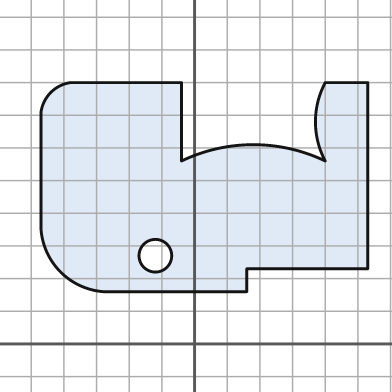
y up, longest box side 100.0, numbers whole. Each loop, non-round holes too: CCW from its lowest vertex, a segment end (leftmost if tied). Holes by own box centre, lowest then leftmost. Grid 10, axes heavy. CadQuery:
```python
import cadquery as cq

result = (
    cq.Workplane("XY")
    .moveTo(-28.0, 16.0)
    .lineTo(16.0, 16.0)
    .lineTo(16.0, 23.0)
    .lineTo(53.0, 23.0)
    .lineTo(53.0, 80.0)
    .lineTo(40.0, 80.0)
    .threePointArc((37.0, 68.0), (40.0, 56.0))
    .threePointArc((18.0, 61.0), (-4.0, 56.0))
    .lineTo(-4.0, 80.0)
    .lineTo(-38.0, 80.0)
    .threePointArc((-44.0, 77.0), (-47.0, 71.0))
    .lineTo(-47.0, 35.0)
    .threePointArc((-41.0, 22.0), (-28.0, 16.0))
    .close()
    .moveTo(-12.0, 27.0)
    .circle(5.0)
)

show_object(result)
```